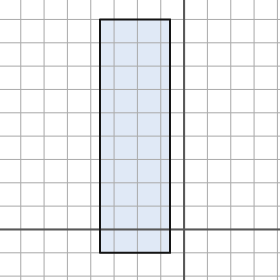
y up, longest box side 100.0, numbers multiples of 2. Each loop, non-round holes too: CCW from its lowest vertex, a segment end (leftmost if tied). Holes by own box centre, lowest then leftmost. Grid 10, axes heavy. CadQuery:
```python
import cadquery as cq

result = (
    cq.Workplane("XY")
    .moveTo(-36.0, -10.0)
    .lineTo(-6.0, -10.0)
    .lineTo(-6.0, 90.0)
    .lineTo(-36.0, 90.0)
    .close()
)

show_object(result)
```